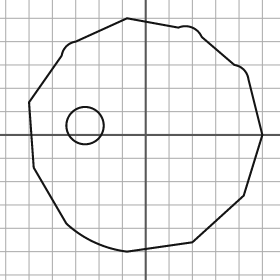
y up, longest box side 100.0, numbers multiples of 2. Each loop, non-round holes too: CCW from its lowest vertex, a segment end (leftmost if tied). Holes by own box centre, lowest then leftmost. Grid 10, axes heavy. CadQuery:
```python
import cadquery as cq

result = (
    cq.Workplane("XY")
    .moveTo(-8.0, -50.0)
    .lineTo(20.0, -46.0)
    .lineTo(42.0, -26.0)
    .lineTo(50.0, 0.0)
    .lineTo(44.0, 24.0)
    .threePointArc((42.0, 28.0), (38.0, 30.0))
    .lineTo(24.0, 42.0)
    .threePointArc((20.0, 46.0), (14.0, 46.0))
    .lineTo(-8.0, 50.0)
    .lineTo(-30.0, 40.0)
    .threePointArc((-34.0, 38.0), (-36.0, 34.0))
    .lineTo(-50.0, 14.0)
    .lineTo(-48.0, -14.0)
    .lineTo(-34.0, -38.0)
    .threePointArc((-22.0, -46.0), (-8.0, -50.0))
    .close()
    .moveTo(-26.0, 4.0)
    .circle(8.0)
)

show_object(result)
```